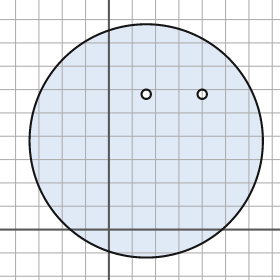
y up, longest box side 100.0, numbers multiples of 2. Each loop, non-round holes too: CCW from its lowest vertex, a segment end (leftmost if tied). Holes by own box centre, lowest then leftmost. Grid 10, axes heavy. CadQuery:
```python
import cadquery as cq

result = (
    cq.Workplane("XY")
    .moveTo(16.0, 38.0)
    .circle(50.0)
    .moveTo(16.0, 58.0)
    .circle(2.0)
    .moveTo(40.0, 58.0)
    .circle(2.0)
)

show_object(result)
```